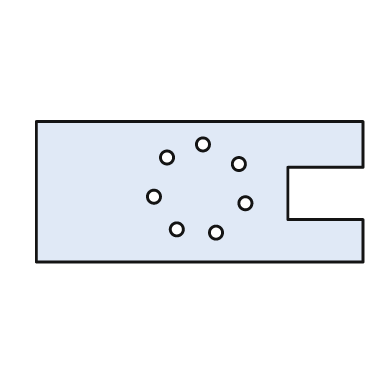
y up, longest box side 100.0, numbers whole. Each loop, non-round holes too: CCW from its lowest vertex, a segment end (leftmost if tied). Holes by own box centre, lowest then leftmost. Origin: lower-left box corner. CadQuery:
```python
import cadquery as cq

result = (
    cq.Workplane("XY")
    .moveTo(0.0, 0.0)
    .lineTo(100.0, 0.0)
    .lineTo(100.0, 13.0)
    .lineTo(77.0, 13.0)
    .lineTo(77.0, 29.0)
    .lineTo(100.0, 29.0)
    .lineTo(100.0, 43.0)
    .lineTo(0.0, 43.0)
    .close()
    .moveTo(55.0, 9.0)
    .circle(2.0)
    .moveTo(43.0, 10.0)
    .circle(2.0)
    .moveTo(64.0, 18.0)
    .circle(2.0)
    .moveTo(36.0, 20.0)
    .circle(2.0)
    .moveTo(62.0, 30.0)
    .circle(2.0)
    .moveTo(40.0, 32.0)
    .circle(2.0)
    .moveTo(51.0, 36.0)
    .circle(2.0)
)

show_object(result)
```